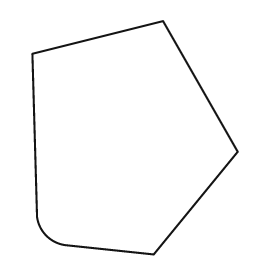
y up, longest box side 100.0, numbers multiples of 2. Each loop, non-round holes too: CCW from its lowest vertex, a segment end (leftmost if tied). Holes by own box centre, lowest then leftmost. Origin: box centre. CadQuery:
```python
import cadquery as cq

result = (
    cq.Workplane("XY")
    .moveTo(8.0, -50.0)
    .lineTo(44.0, -6.0)
    .lineTo(12.0, 50.0)
    .lineTo(-44.0, 36.0)
    .lineTo(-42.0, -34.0)
    .threePointArc((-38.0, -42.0), (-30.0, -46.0))
    .close()
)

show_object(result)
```